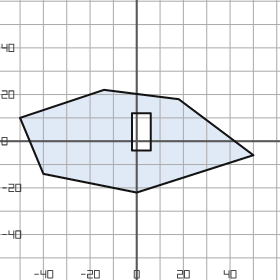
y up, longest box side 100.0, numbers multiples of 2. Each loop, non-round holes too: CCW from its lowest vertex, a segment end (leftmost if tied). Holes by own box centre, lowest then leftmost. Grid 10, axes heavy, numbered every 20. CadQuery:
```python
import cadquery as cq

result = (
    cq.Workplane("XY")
    .moveTo(0.0, -22.0)
    .lineTo(50.0, -6.0)
    .lineTo(18.0, 18.0)
    .lineTo(-14.0, 22.0)
    .lineTo(-50.0, 10.0)
    .lineTo(-40.0, -14.0)
    .close()
    .moveTo(-2.0, -4.0)
    .lineTo(6.0, -4.0)
    .lineTo(6.0, 12.0)
    .lineTo(-2.0, 12.0)
    .close()
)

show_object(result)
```